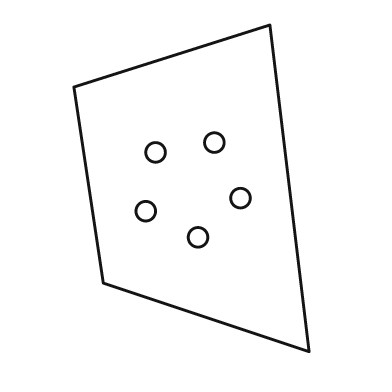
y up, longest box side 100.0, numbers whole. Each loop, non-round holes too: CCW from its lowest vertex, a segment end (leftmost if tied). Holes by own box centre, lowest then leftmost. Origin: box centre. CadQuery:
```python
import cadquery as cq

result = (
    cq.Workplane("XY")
    .moveTo(36.0, -50.0)
    .lineTo(24.0, 50.0)
    .lineTo(-36.0, 31.0)
    .lineTo(-27.0, -29.0)
    .close()
    .moveTo(2.0, -15.0)
    .circle(3.0)
    .moveTo(-14.0, -7.0)
    .circle(3.0)
    .moveTo(15.0, -3.0)
    .circle(3.0)
    .moveTo(-11.0, 11.0)
    .circle(3.0)
    .moveTo(7.0, 14.0)
    .circle(3.0)
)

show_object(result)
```